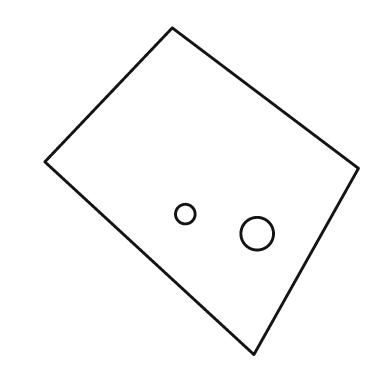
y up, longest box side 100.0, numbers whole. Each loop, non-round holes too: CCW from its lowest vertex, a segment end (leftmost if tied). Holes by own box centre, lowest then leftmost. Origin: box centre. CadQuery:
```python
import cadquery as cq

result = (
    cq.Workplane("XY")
    .moveTo(16.0, -50.0)
    .lineTo(48.0, 7.0)
    .lineTo(-9.0, 50.0)
    .lineTo(-48.0, 9.0)
    .close()
    .moveTo(17.0, -13.0)
    .circle(5.0)
    .moveTo(-5.0, -7.0)
    .circle(3.0)
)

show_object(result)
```